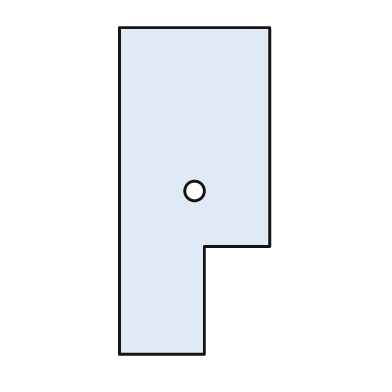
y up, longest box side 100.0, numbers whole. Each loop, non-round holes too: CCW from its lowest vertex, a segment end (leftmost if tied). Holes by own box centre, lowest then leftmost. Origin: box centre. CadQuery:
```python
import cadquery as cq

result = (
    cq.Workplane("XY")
    .moveTo(-23.0, -50.0)
    .lineTo(3.0, -50.0)
    .lineTo(3.0, -17.0)
    .lineTo(23.0, -17.0)
    .lineTo(23.0, 50.0)
    .lineTo(-23.0, 50.0)
    .close()
    .moveTo(0.0, 0.0)
    .circle(3.0)
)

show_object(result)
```